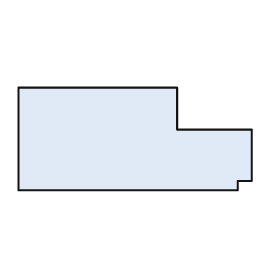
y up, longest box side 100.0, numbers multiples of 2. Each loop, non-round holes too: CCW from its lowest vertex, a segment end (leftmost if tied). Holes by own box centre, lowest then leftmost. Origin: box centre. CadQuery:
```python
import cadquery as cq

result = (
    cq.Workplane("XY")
    .moveTo(-50.0, -22.0)
    .lineTo(44.0, -22.0)
    .lineTo(44.0, -18.0)
    .lineTo(50.0, -18.0)
    .lineTo(50.0, 4.0)
    .lineTo(18.0, 4.0)
    .lineTo(18.0, 22.0)
    .lineTo(-50.0, 22.0)
    .close()
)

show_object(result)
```